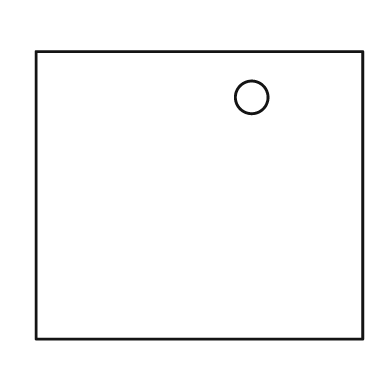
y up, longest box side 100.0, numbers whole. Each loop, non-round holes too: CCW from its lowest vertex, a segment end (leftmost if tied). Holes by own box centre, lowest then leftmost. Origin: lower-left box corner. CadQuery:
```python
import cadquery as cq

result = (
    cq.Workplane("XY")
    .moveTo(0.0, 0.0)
    .lineTo(100.0, 0.0)
    .lineTo(100.0, 88.0)
    .lineTo(0.0, 88.0)
    .close()
    .moveTo(66.0, 74.0)
    .circle(5.0)
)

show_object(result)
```